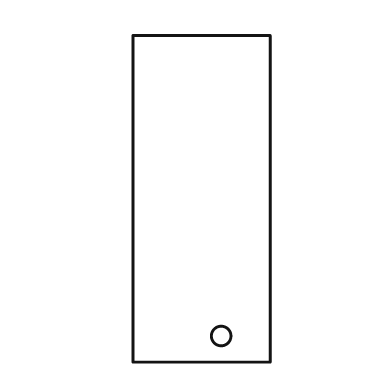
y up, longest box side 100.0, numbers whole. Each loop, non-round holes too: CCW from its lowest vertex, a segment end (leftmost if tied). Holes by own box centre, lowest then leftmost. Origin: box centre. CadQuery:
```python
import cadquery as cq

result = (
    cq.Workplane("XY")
    .moveTo(-21.0, -50.0)
    .lineTo(21.0, -50.0)
    .lineTo(21.0, 50.0)
    .lineTo(-21.0, 50.0)
    .close()
    .moveTo(6.0, -42.0)
    .circle(3.0)
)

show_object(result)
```